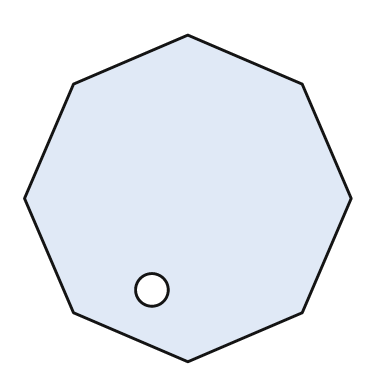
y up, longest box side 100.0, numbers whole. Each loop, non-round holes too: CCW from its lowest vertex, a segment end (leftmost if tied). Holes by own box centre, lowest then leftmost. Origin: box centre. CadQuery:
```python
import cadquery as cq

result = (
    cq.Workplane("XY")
    .moveTo(0.0, -50.0)
    .lineTo(35.0, -35.0)
    .lineTo(50.0, 0.0)
    .lineTo(35.0, 35.0)
    .lineTo(0.0, 50.0)
    .lineTo(-35.0, 35.0)
    .lineTo(-50.0, 0.0)
    .lineTo(-35.0, -35.0)
    .close()
    .moveTo(-11.0, -28.0)
    .circle(5.0)
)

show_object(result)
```